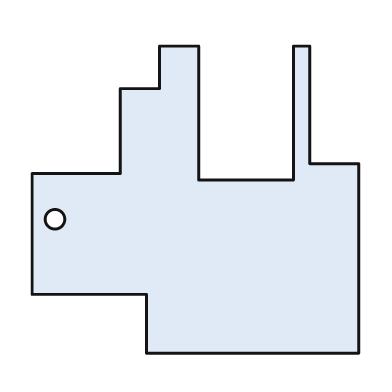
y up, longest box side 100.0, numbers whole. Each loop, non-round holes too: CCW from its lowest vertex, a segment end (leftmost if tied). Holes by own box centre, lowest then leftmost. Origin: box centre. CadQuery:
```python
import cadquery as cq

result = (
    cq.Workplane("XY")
    .moveTo(-15.0, -47.0)
    .lineTo(50.0, -47.0)
    .lineTo(50.0, 11.0)
    .lineTo(35.0, 11.0)
    .lineTo(35.0, 47.0)
    .lineTo(30.0, 47.0)
    .lineTo(30.0, 6.0)
    .lineTo(1.0, 6.0)
    .lineTo(1.0, 47.0)
    .lineTo(-11.0, 47.0)
    .lineTo(-11.0, 34.0)
    .lineTo(-23.0, 34.0)
    .lineTo(-23.0, 8.0)
    .lineTo(-50.0, 8.0)
    .lineTo(-50.0, -29.0)
    .lineTo(-15.0, -29.0)
    .close()
    .moveTo(-43.0, -6.0)
    .circle(3.0)
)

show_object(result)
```